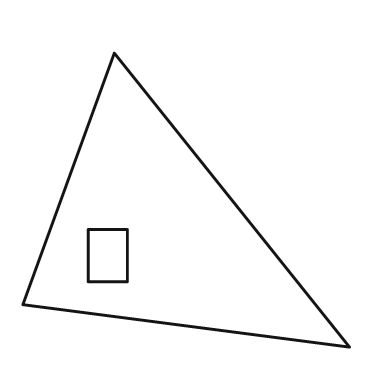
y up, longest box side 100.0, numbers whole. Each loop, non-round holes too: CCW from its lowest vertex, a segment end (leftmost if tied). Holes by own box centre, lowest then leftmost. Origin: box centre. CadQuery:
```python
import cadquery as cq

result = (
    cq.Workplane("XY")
    .moveTo(50.0, -45.0)
    .lineTo(-22.0, 45.0)
    .lineTo(-50.0, -32.0)
    .close()
    .moveTo(-30.0, -25.0)
    .lineTo(-18.0, -25.0)
    .lineTo(-18.0, -9.0)
    .lineTo(-30.0, -9.0)
    .close()
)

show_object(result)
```